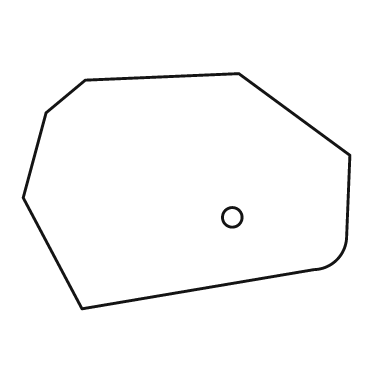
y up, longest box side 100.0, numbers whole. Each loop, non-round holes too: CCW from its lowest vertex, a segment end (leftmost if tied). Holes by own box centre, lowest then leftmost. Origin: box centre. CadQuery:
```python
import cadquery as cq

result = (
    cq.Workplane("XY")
    .moveTo(-32.0, -36.0)
    .lineTo(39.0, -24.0)
    .threePointArc((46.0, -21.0), (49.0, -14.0))
    .lineTo(50.0, 11.0)
    .lineTo(16.0, 36.0)
    .lineTo(-31.0, 34.0)
    .lineTo(-43.0, 24.0)
    .lineTo(-50.0, -2.0)
    .close()
    .moveTo(14.0, -8.0)
    .circle(3.0)
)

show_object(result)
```